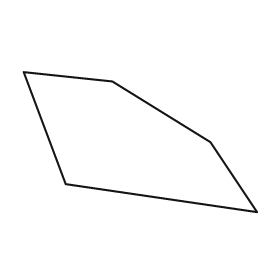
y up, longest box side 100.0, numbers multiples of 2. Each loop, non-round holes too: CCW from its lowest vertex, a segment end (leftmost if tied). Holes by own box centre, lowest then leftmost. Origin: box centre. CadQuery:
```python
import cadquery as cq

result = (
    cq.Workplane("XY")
    .moveTo(50.0, -30.0)
    .lineTo(30.0, 0.0)
    .lineTo(-12.0, 26.0)
    .lineTo(-50.0, 30.0)
    .lineTo(-32.0, -18.0)
    .close()
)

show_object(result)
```